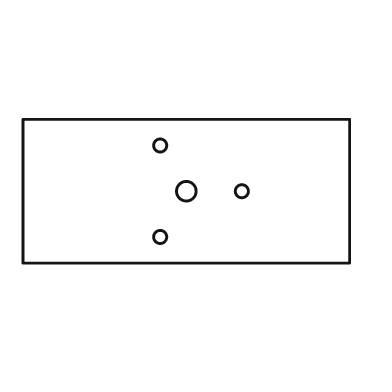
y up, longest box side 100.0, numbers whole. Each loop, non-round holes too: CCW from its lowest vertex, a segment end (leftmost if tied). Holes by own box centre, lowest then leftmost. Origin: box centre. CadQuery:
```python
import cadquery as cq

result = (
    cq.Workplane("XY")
    .moveTo(-50.0, -22.0)
    .lineTo(50.0, -22.0)
    .lineTo(50.0, 22.0)
    .lineTo(-50.0, 22.0)
    .close()
    .moveTo(-8.0, -14.0)
    .circle(2.0)
    .moveTo(0.0, 0.0)
    .circle(3.0)
    .moveTo(17.0, 0.0)
    .circle(2.0)
    .moveTo(-8.0, 14.0)
    .circle(2.0)
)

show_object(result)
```